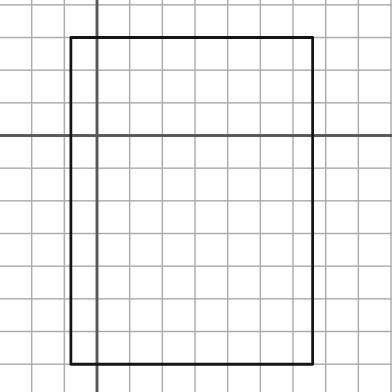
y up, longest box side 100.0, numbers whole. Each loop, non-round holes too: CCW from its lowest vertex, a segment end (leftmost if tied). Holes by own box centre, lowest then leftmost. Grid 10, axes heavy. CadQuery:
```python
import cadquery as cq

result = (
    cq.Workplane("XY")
    .moveTo(-8.0, -70.0)
    .lineTo(66.0, -70.0)
    .lineTo(66.0, 30.0)
    .lineTo(-8.0, 30.0)
    .close()
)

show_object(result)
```